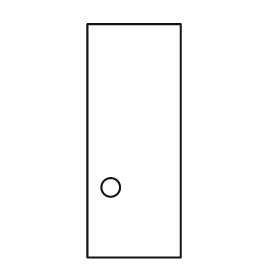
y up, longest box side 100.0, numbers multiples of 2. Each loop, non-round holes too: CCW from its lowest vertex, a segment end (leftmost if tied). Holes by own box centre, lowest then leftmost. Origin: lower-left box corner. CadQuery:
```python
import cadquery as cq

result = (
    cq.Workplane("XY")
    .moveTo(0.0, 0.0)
    .lineTo(40.0, 0.0)
    .lineTo(40.0, 100.0)
    .lineTo(0.0, 100.0)
    .close()
    .moveTo(10.0, 30.0)
    .circle(4.0)
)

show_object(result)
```